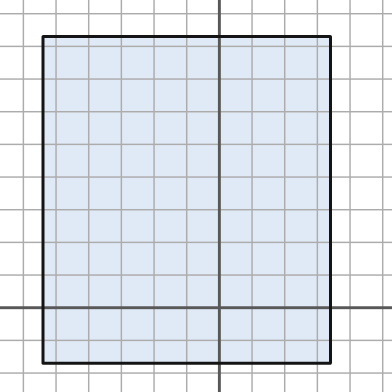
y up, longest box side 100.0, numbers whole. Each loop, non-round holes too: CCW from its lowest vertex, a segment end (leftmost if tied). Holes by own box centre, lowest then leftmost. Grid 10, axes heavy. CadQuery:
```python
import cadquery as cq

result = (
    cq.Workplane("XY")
    .moveTo(-54.0, -17.0)
    .lineTo(34.0, -17.0)
    .lineTo(34.0, 83.0)
    .lineTo(-54.0, 83.0)
    .close()
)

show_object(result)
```